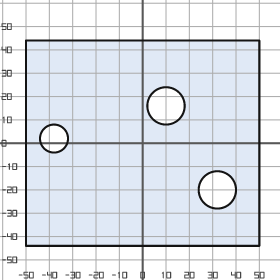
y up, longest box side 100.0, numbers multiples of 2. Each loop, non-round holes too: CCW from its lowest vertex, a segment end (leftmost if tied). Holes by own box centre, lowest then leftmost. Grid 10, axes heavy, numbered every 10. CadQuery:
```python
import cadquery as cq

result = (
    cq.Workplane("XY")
    .moveTo(-50.0, -44.0)
    .lineTo(50.0, -44.0)
    .lineTo(50.0, 44.0)
    .lineTo(-50.0, 44.0)
    .close()
    .moveTo(32.0, -20.0)
    .circle(8.0)
    .moveTo(-38.0, 2.0)
    .circle(6.0)
    .moveTo(10.0, 16.0)
    .circle(8.0)
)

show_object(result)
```